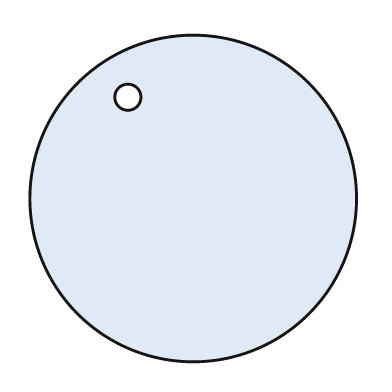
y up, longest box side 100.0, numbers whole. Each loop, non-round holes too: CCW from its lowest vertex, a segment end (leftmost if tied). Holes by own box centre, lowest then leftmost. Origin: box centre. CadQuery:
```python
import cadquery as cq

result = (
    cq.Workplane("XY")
    .moveTo(0.0, 0.0)
    .circle(50.0)
    .moveTo(-20.0, 31.0)
    .circle(4.0)
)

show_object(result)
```